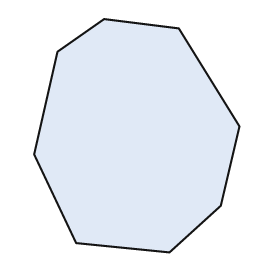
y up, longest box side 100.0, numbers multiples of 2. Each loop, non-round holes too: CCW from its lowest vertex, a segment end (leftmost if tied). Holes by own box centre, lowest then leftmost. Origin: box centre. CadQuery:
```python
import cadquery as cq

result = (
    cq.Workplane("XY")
    .moveTo(14.0, -50.0)
    .lineTo(36.0, -30.0)
    .lineTo(44.0, 4.0)
    .lineTo(18.0, 46.0)
    .lineTo(-14.0, 50.0)
    .lineTo(-34.0, 36.0)
    .lineTo(-44.0, -8.0)
    .lineTo(-26.0, -46.0)
    .close()
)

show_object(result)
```